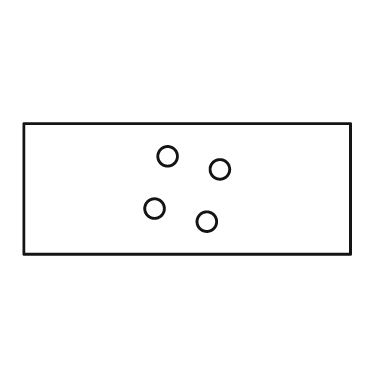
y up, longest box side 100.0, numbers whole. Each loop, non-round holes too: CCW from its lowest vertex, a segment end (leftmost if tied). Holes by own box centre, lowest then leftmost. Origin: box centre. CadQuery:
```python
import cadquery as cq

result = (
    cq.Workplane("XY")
    .moveTo(-50.0, -20.0)
    .lineTo(50.0, -20.0)
    .lineTo(50.0, 20.0)
    .lineTo(-50.0, 20.0)
    .close()
    .moveTo(6.0, -10.0)
    .circle(3.0)
    .moveTo(-10.0, -6.0)
    .circle(3.0)
    .moveTo(10.0, 6.0)
    .circle(3.0)
    .moveTo(-6.0, 10.0)
    .circle(3.0)
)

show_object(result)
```